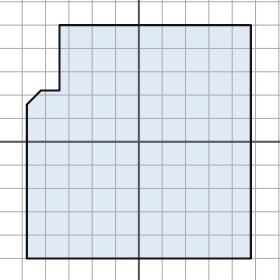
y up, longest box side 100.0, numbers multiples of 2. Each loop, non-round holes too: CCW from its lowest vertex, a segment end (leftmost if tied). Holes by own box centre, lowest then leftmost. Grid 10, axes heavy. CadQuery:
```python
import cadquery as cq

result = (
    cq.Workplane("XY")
    .moveTo(-48.0, -50.0)
    .lineTo(48.0, -50.0)
    .lineTo(48.0, 50.0)
    .lineTo(-34.0, 50.0)
    .lineTo(-34.0, 22.0)
    .lineTo(-42.0, 22.0)
    .lineTo(-48.0, 16.0)
    .close()
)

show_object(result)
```